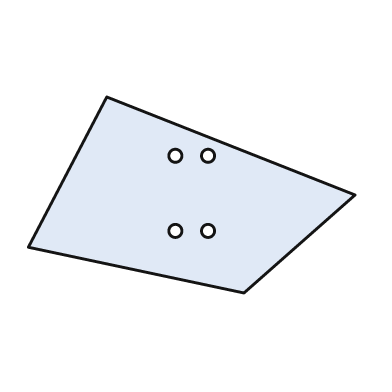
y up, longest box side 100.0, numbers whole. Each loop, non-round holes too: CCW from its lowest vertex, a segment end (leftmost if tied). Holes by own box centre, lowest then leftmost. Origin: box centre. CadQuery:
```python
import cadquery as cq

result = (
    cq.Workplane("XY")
    .moveTo(16.0, -30.0)
    .lineTo(50.0, 0.0)
    .lineTo(-26.0, 30.0)
    .lineTo(-50.0, -16.0)
    .close()
    .moveTo(-5.0, -11.0)
    .circle(2.0)
    .moveTo(5.0, -11.0)
    .circle(2.0)
    .moveTo(-5.0, 12.0)
    .circle(2.0)
    .moveTo(5.0, 12.0)
    .circle(2.0)
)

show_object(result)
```